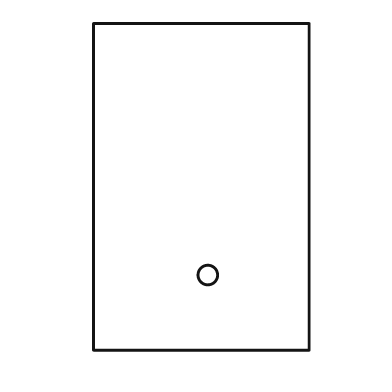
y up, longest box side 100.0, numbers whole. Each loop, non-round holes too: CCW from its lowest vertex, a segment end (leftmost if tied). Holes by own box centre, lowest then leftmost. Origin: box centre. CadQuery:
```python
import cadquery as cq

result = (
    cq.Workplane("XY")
    .moveTo(-33.0, -50.0)
    .lineTo(33.0, -50.0)
    .lineTo(33.0, 50.0)
    .lineTo(-33.0, 50.0)
    .close()
    .moveTo(2.0, -27.0)
    .circle(3.0)
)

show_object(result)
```